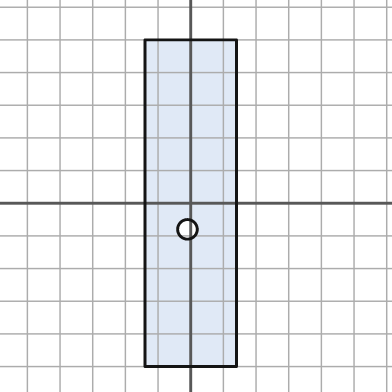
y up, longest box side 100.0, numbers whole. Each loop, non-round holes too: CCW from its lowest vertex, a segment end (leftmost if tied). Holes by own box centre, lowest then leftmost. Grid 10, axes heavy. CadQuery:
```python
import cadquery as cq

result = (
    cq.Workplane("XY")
    .moveTo(-14.0, -50.0)
    .lineTo(14.0, -50.0)
    .lineTo(14.0, 50.0)
    .lineTo(-14.0, 50.0)
    .close()
    .moveTo(-1.0, -8.0)
    .circle(3.0)
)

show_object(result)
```